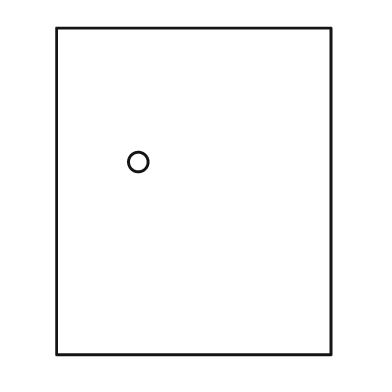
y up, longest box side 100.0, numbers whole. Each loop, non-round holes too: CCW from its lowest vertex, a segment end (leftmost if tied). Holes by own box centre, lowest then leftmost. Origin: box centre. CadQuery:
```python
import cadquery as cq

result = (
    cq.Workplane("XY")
    .moveTo(-42.0, -50.0)
    .lineTo(42.0, -50.0)
    .lineTo(42.0, 50.0)
    .lineTo(-42.0, 50.0)
    .close()
    .moveTo(-17.0, 9.0)
    .circle(3.0)
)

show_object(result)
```